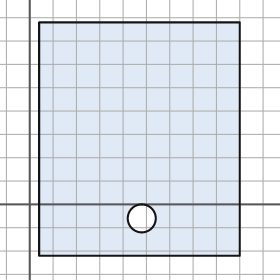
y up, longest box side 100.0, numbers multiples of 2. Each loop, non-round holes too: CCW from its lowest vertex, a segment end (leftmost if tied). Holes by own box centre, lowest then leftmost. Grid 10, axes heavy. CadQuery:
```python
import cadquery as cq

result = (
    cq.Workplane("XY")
    .moveTo(4.0, -22.0)
    .lineTo(90.0, -22.0)
    .lineTo(90.0, 78.0)
    .lineTo(4.0, 78.0)
    .close()
    .moveTo(48.0, -6.0)
    .circle(6.0)
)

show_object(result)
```